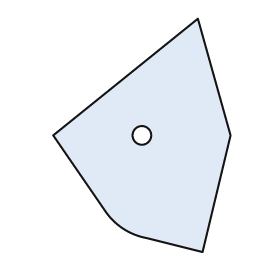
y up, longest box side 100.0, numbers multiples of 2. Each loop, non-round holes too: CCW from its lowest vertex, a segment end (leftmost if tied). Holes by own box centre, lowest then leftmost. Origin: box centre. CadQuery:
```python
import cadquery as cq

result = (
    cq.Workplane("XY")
    .moveTo(26.0, -50.0)
    .lineTo(38.0, 0.0)
    .lineTo(24.0, 50.0)
    .lineTo(-38.0, 0.0)
    .lineTo(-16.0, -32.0)
    .threePointArc((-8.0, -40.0), (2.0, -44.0))
    .close()
    .moveTo(0.0, 0.0)
    .circle(4.0)
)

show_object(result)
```